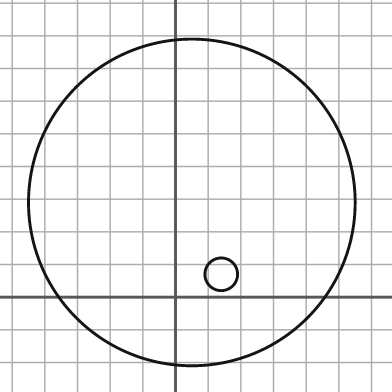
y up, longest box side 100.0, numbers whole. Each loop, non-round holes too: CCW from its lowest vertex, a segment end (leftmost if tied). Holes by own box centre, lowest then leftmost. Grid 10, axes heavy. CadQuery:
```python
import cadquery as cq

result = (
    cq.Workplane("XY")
    .moveTo(5.0, 29.0)
    .circle(50.0)
    .moveTo(14.0, 7.0)
    .circle(5.0)
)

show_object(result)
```